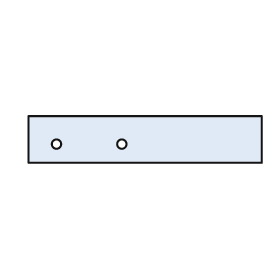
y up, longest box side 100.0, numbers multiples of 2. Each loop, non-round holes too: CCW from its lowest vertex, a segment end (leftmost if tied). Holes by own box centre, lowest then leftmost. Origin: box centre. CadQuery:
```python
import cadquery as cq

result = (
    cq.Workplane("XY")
    .moveTo(-50.0, -10.0)
    .lineTo(50.0, -10.0)
    .lineTo(50.0, 10.0)
    .lineTo(-50.0, 10.0)
    .close()
    .moveTo(-38.0, -2.0)
    .circle(2.0)
    .moveTo(-10.0, -2.0)
    .circle(2.0)
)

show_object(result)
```